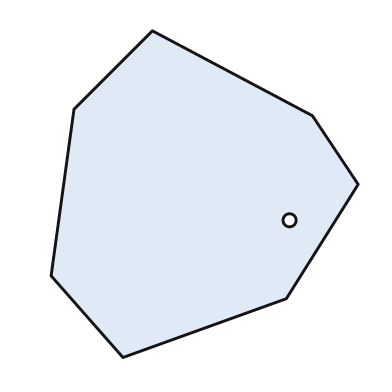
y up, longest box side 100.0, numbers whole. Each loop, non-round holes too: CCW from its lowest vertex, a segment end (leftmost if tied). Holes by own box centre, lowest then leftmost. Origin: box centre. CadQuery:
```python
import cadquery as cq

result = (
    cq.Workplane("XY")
    .moveTo(-25.0, -50.0)
    .lineTo(25.0, -32.0)
    .lineTo(47.0, 3.0)
    .lineTo(33.0, 24.0)
    .lineTo(-16.0, 50.0)
    .lineTo(-40.0, 26.0)
    .lineTo(-47.0, -25.0)
    .close()
    .moveTo(26.0, -8.0)
    .circle(2.0)
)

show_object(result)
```